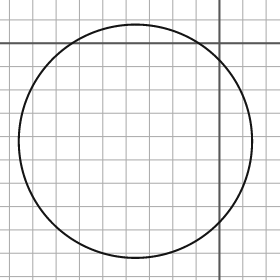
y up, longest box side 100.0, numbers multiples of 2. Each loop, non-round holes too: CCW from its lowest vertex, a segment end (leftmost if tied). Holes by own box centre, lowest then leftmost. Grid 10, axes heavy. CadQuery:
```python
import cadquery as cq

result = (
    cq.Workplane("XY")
    .moveTo(-36.0, -42.0)
    .circle(50.0)
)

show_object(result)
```